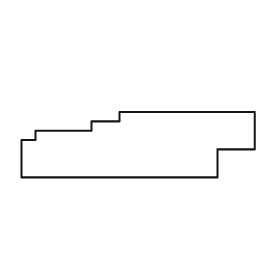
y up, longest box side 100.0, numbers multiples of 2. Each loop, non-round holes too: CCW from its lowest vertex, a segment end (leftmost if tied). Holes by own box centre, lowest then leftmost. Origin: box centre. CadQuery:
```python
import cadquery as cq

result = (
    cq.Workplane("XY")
    .moveTo(-50.0, -14.0)
    .lineTo(34.0, -14.0)
    .lineTo(34.0, -2.0)
    .lineTo(50.0, -2.0)
    .lineTo(50.0, 14.0)
    .lineTo(-8.0, 14.0)
    .lineTo(-8.0, 10.0)
    .lineTo(-20.0, 10.0)
    .lineTo(-20.0, 6.0)
    .lineTo(-44.0, 6.0)
    .lineTo(-44.0, 2.0)
    .lineTo(-50.0, 2.0)
    .close()
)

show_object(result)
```